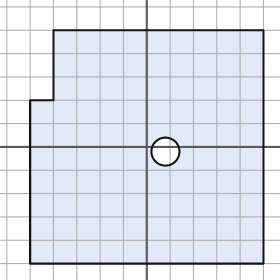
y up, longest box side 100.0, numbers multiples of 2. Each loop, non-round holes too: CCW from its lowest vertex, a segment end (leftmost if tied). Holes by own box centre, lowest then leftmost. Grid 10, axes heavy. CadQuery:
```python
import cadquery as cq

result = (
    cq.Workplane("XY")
    .moveTo(-50.0, -50.0)
    .lineTo(50.0, -50.0)
    .lineTo(50.0, 50.0)
    .lineTo(-40.0, 50.0)
    .lineTo(-40.0, 20.0)
    .lineTo(-50.0, 20.0)
    .close()
    .moveTo(8.0, -2.0)
    .circle(6.0)
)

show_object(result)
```